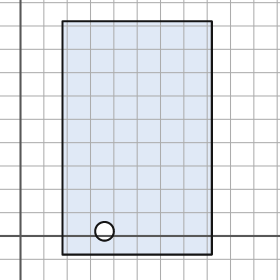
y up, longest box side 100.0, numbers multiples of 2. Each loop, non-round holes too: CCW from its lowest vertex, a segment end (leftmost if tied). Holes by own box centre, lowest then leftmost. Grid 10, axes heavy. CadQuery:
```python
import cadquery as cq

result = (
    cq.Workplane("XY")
    .moveTo(18.0, -8.0)
    .lineTo(82.0, -8.0)
    .lineTo(82.0, 92.0)
    .lineTo(18.0, 92.0)
    .close()
    .moveTo(36.0, 2.0)
    .circle(4.0)
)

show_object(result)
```